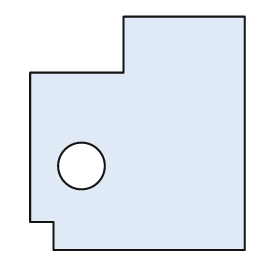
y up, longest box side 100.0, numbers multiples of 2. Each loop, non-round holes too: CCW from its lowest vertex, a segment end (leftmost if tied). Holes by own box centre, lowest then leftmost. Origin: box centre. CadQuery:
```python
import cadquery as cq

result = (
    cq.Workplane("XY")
    .moveTo(-36.0, -50.0)
    .lineTo(46.0, -50.0)
    .lineTo(46.0, 50.0)
    .lineTo(-6.0, 50.0)
    .lineTo(-6.0, 26.0)
    .lineTo(-46.0, 26.0)
    .lineTo(-46.0, -38.0)
    .lineTo(-36.0, -38.0)
    .close()
    .moveTo(-24.0, -14.0)
    .circle(10.0)
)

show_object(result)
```